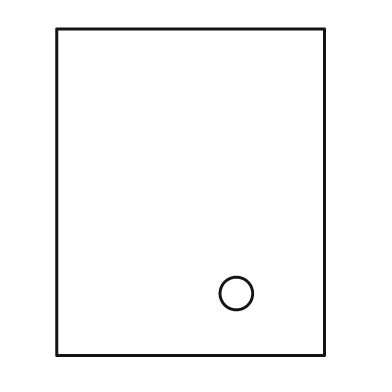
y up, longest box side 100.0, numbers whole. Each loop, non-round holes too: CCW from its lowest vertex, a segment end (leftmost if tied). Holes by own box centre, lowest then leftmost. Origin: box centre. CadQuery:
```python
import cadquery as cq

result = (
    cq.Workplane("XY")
    .moveTo(-41.0, -50.0)
    .lineTo(41.0, -50.0)
    .lineTo(41.0, 50.0)
    .lineTo(-41.0, 50.0)
    .close()
    .moveTo(14.0, -31.0)
    .circle(5.0)
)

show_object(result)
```